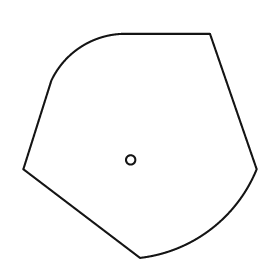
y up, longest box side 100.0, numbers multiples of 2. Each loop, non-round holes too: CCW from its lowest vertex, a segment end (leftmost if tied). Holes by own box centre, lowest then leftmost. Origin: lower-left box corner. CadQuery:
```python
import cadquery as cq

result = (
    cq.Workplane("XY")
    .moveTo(50.0, 0.0)
    .threePointArc((80.0, 12.0), (100.0, 38.0))
    .lineTo(80.0, 96.0)
    .lineTo(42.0, 96.0)
    .threePointArc((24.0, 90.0), (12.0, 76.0))
    .lineTo(0.0, 38.0)
    .close()
    .moveTo(46.0, 42.0)
    .circle(2.0)
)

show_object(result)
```